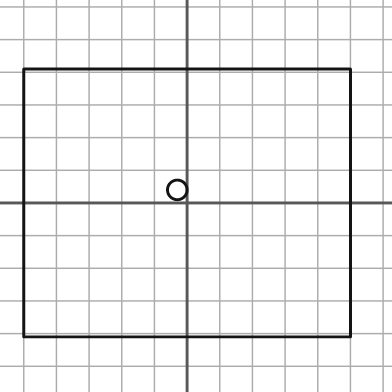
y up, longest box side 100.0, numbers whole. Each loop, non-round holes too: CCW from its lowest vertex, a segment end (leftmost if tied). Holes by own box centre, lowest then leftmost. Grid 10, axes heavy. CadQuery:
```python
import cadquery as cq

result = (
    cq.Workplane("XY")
    .moveTo(-50.0, -41.0)
    .lineTo(50.0, -41.0)
    .lineTo(50.0, 41.0)
    .lineTo(-50.0, 41.0)
    .close()
    .moveTo(-3.0, 4.0)
    .circle(3.0)
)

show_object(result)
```